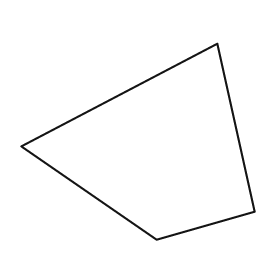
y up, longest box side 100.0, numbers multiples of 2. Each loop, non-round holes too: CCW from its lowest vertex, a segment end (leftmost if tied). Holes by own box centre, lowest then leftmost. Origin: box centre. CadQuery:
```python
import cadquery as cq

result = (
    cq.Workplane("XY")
    .moveTo(8.0, -42.0)
    .lineTo(50.0, -30.0)
    .lineTo(34.0, 42.0)
    .lineTo(-50.0, -2.0)
    .close()
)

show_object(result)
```